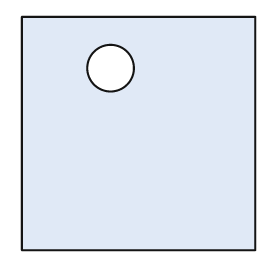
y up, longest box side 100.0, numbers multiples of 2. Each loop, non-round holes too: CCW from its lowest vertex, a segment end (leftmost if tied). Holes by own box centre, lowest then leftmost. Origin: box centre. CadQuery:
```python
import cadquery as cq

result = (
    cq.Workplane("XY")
    .moveTo(-50.0, -50.0)
    .lineTo(50.0, -50.0)
    .lineTo(50.0, 50.0)
    .lineTo(-50.0, 50.0)
    .close()
    .moveTo(-12.0, 28.0)
    .circle(10.0)
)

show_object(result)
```